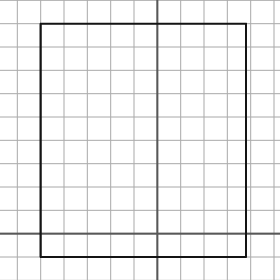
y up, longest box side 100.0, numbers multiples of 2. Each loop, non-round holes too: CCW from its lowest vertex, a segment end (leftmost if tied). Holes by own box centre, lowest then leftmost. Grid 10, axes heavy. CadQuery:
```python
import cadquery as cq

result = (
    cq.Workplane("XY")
    .moveTo(-50.0, -10.0)
    .lineTo(38.0, -10.0)
    .lineTo(38.0, 90.0)
    .lineTo(-50.0, 90.0)
    .close()
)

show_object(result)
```